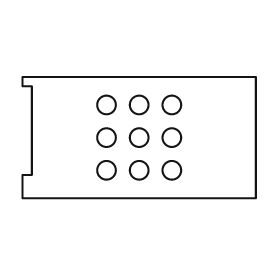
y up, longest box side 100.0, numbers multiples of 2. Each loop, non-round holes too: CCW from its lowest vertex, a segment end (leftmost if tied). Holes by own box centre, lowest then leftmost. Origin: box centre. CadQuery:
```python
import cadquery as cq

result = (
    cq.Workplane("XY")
    .moveTo(-50.0, -26.0)
    .lineTo(50.0, -26.0)
    .lineTo(50.0, 26.0)
    .lineTo(-50.0, 26.0)
    .lineTo(-50.0, 22.0)
    .lineTo(-46.0, 22.0)
    .lineTo(-46.0, -16.0)
    .lineTo(-50.0, -16.0)
    .close()
    .moveTo(-14.0, -14.0)
    .circle(4.0)
    .moveTo(0.0, -14.0)
    .circle(4.0)
    .moveTo(14.0, -14.0)
    .circle(4.0)
    .moveTo(-14.0, 0.0)
    .circle(4.0)
    .moveTo(0.0, 0.0)
    .circle(4.0)
    .moveTo(14.0, 0.0)
    .circle(4.0)
    .moveTo(-14.0, 14.0)
    .circle(4.0)
    .moveTo(0.0, 14.0)
    .circle(4.0)
    .moveTo(14.0, 14.0)
    .circle(4.0)
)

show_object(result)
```